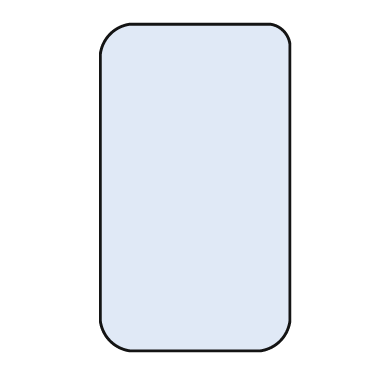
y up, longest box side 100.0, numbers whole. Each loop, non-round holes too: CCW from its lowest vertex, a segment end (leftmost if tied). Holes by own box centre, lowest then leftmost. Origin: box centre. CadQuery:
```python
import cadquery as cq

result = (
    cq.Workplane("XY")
    .moveTo(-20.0, -50.0)
    .lineTo(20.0, -50.0)
    .threePointArc((26.0, -47.0), (29.0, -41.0))
    .lineTo(29.0, 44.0)
    .threePointArc((27.0, 48.0), (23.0, 50.0))
    .lineTo(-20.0, 50.0)
    .threePointArc((-26.0, 47.0), (-29.0, 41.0))
    .lineTo(-29.0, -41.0)
    .threePointArc((-26.0, -47.0), (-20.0, -50.0))
    .close()
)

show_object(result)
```